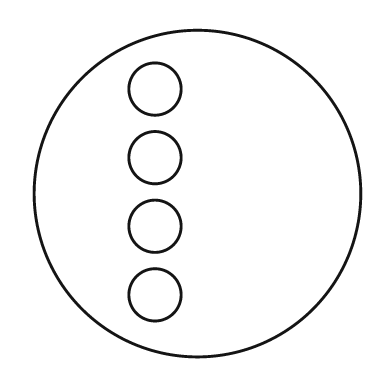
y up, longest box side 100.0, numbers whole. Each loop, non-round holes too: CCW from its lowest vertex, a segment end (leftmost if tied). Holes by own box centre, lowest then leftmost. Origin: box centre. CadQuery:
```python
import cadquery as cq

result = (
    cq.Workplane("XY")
    .moveTo(0.0, 0.0)
    .circle(50.0)
    .moveTo(-13.0, -31.0)
    .circle(8.0)
    .moveTo(-13.0, -10.0)
    .circle(8.0)
    .moveTo(-13.0, 11.0)
    .circle(8.0)
    .moveTo(-13.0, 32.0)
    .circle(8.0)
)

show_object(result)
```